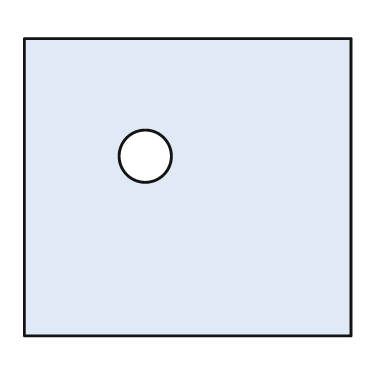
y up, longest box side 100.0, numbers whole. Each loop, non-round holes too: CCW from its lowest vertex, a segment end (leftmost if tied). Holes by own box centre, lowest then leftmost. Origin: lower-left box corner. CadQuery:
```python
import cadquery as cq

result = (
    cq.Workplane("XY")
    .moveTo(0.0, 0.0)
    .lineTo(100.0, 0.0)
    .lineTo(100.0, 91.0)
    .lineTo(0.0, 91.0)
    .close()
    .moveTo(37.0, 55.0)
    .circle(8.0)
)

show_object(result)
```